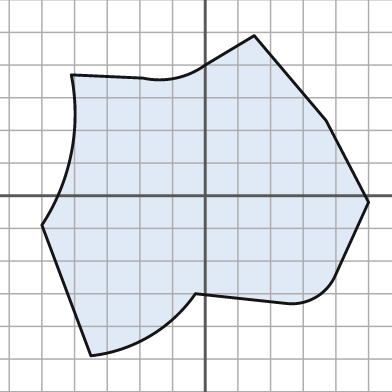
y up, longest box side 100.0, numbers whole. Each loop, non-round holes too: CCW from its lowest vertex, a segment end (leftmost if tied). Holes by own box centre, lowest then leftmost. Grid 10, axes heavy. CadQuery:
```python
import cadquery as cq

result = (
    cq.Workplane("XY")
    .moveTo(-35.0, -49.0)
    .threePointArc((-17.0, -43.0), (-3.0, -30.0))
    .lineTo(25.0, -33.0)
    .threePointArc((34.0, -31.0), (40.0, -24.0))
    .lineTo(50.0, -2.0)
    .lineTo(37.0, 23.0)
    .lineTo(15.0, 49.0)
    .lineTo(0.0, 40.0)
    .threePointArc((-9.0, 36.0), (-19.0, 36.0))
    .lineTo(-41.0, 37.0)
    .threePointArc((-41.0, 13.0), (-50.0, -9.0))
    .close()
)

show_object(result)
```